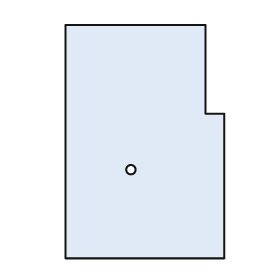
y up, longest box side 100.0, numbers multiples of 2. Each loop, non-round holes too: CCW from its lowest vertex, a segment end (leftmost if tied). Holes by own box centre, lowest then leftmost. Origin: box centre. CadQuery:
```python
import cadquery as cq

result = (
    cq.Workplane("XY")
    .moveTo(-34.0, -50.0)
    .lineTo(34.0, -50.0)
    .lineTo(34.0, 12.0)
    .lineTo(26.0, 12.0)
    .lineTo(26.0, 50.0)
    .lineTo(-34.0, 50.0)
    .close()
    .moveTo(-6.0, -12.0)
    .circle(2.0)
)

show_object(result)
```